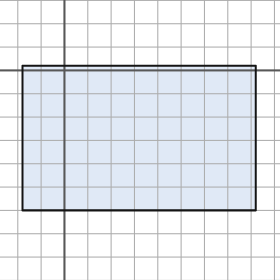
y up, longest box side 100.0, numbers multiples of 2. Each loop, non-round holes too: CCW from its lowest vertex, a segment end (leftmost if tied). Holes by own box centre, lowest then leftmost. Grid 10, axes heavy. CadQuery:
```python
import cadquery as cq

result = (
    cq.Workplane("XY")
    .moveTo(-18.0, -60.0)
    .lineTo(82.0, -60.0)
    .lineTo(82.0, 2.0)
    .lineTo(-18.0, 2.0)
    .close()
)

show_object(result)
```